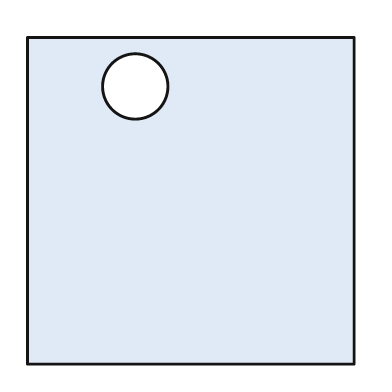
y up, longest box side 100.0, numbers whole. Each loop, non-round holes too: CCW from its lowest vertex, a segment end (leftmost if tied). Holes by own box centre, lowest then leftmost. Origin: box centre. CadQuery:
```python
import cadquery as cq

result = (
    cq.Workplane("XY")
    .moveTo(-50.0, -50.0)
    .lineTo(50.0, -50.0)
    .lineTo(50.0, 50.0)
    .lineTo(-50.0, 50.0)
    .close()
    .moveTo(-17.0, 35.0)
    .circle(10.0)
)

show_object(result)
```